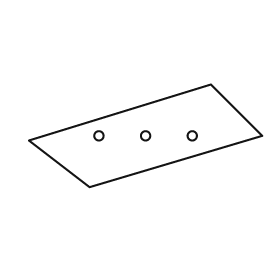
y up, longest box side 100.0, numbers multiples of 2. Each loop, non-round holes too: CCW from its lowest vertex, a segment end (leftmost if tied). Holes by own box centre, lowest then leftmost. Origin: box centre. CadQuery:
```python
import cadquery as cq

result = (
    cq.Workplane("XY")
    .moveTo(-24.0, -22.0)
    .lineTo(50.0, 0.0)
    .lineTo(28.0, 22.0)
    .lineTo(-50.0, -2.0)
    .close()
    .moveTo(-20.0, 0.0)
    .circle(2.0)
    .moveTo(0.0, 0.0)
    .circle(2.0)
    .moveTo(20.0, 0.0)
    .circle(2.0)
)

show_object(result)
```